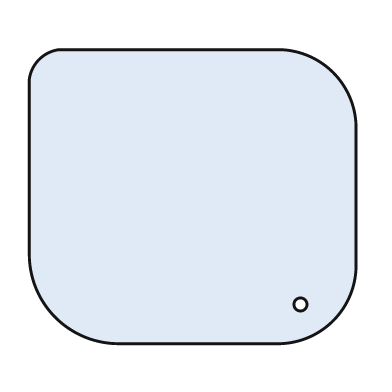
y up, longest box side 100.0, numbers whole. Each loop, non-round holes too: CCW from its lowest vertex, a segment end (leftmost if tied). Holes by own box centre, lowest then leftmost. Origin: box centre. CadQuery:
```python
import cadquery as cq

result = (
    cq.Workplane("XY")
    .moveTo(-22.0, -45.0)
    .lineTo(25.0, -45.0)
    .threePointArc((43.0, -38.0), (50.0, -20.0))
    .lineTo(50.0, 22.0)
    .threePointArc((43.0, 38.0), (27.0, 45.0))
    .lineTo(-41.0, 45.0)
    .threePointArc((-47.0, 42.0), (-50.0, 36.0))
    .lineTo(-50.0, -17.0)
    .threePointArc((-42.0, -37.0), (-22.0, -45.0))
    .close()
    .moveTo(33.0, -33.0)
    .circle(2.0)
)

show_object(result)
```